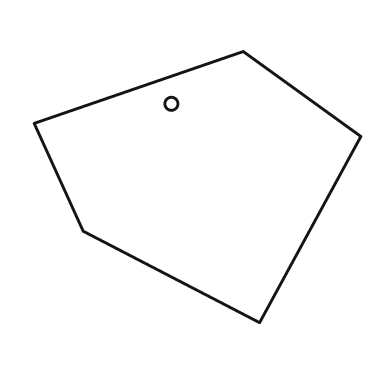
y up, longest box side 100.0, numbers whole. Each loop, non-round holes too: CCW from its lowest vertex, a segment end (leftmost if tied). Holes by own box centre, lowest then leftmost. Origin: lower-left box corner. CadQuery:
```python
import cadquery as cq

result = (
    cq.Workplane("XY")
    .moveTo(69.0, 0.0)
    .lineTo(100.0, 57.0)
    .lineTo(64.0, 83.0)
    .lineTo(0.0, 61.0)
    .lineTo(15.0, 28.0)
    .close()
    .moveTo(42.0, 67.0)
    .circle(2.0)
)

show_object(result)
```